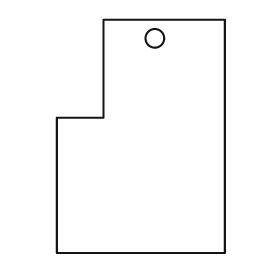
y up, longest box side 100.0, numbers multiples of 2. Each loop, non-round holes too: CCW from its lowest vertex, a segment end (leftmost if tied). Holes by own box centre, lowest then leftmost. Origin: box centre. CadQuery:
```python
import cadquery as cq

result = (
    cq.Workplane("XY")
    .moveTo(-36.0, -50.0)
    .lineTo(36.0, -50.0)
    .lineTo(36.0, 50.0)
    .lineTo(-16.0, 50.0)
    .lineTo(-16.0, 8.0)
    .lineTo(-36.0, 8.0)
    .close()
    .moveTo(6.0, 42.0)
    .circle(4.0)
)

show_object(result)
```